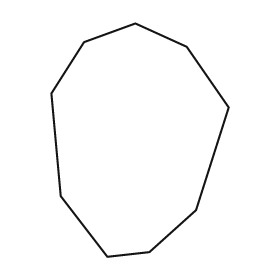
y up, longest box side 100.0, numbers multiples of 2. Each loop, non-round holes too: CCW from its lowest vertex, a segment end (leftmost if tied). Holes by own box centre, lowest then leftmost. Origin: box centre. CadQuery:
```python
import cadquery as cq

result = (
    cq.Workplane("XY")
    .moveTo(-14.0, -50.0)
    .lineTo(4.0, -48.0)
    .lineTo(24.0, -30.0)
    .lineTo(38.0, 14.0)
    .lineTo(20.0, 40.0)
    .lineTo(-2.0, 50.0)
    .lineTo(-24.0, 42.0)
    .lineTo(-38.0, 20.0)
    .lineTo(-34.0, -24.0)
    .close()
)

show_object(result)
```